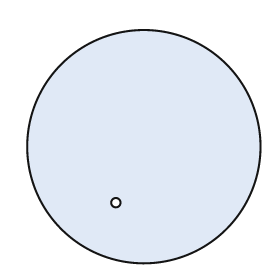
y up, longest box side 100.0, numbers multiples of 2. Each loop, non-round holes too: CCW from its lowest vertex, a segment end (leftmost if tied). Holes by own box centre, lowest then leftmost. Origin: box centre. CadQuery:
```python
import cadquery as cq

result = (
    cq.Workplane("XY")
    .moveTo(0.0, 0.0)
    .circle(50.0)
    .moveTo(-12.0, -24.0)
    .circle(2.0)
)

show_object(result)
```